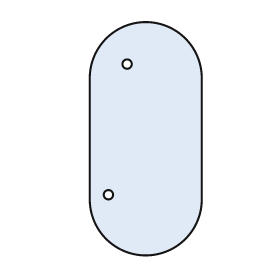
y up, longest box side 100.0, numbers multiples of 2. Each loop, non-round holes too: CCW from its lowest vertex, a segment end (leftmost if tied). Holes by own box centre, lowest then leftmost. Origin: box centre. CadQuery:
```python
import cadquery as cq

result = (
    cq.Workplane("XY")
    .moveTo(-24.0, -26.0)
    .threePointArc((0.0, -50.0), (24.0, -26.0))
    .lineTo(24.0, 26.0)
    .threePointArc((0.0, 50.0), (-24.0, 26.0))
    .close()
    .moveTo(-16.0, -24.0)
    .circle(2.0)
    .moveTo(-8.0, 32.0)
    .circle(2.0)
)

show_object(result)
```